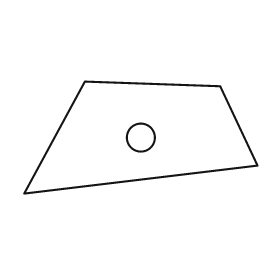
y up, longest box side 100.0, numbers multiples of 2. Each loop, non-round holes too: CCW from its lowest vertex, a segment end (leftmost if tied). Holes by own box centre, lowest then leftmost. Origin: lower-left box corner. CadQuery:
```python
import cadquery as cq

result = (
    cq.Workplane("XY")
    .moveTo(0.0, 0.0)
    .lineTo(100.0, 12.0)
    .lineTo(84.0, 46.0)
    .lineTo(26.0, 48.0)
    .close()
    .moveTo(50.0, 24.0)
    .circle(6.0)
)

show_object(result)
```